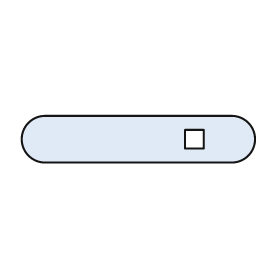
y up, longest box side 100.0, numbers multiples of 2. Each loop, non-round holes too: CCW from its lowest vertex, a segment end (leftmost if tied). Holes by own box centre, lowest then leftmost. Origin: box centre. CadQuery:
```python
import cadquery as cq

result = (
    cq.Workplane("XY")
    .moveTo(-40.0, -10.0)
    .lineTo(40.0, -10.0)
    .threePointArc((50.0, 0.0), (40.0, 10.0))
    .lineTo(-40.0, 10.0)
    .threePointArc((-50.0, 0.0), (-40.0, -10.0))
    .close()
    .moveTo(20.0, -4.0)
    .lineTo(28.0, -4.0)
    .lineTo(28.0, 4.0)
    .lineTo(20.0, 4.0)
    .close()
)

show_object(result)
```